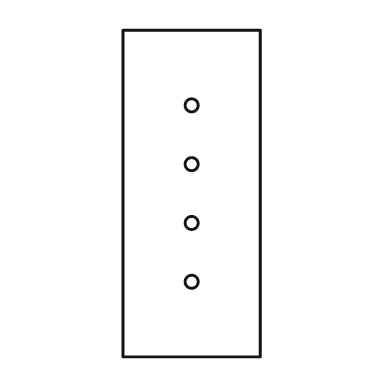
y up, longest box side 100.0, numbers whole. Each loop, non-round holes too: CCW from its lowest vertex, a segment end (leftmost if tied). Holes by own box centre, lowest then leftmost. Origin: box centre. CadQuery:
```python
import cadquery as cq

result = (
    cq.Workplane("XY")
    .moveTo(-21.0, -50.0)
    .lineTo(21.0, -50.0)
    .lineTo(21.0, 50.0)
    .lineTo(-21.0, 50.0)
    .close()
    .moveTo(0.0, -27.0)
    .circle(2.0)
    .moveTo(0.0, -9.0)
    .circle(2.0)
    .moveTo(0.0, 9.0)
    .circle(2.0)
    .moveTo(0.0, 27.0)
    .circle(2.0)
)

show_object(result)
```